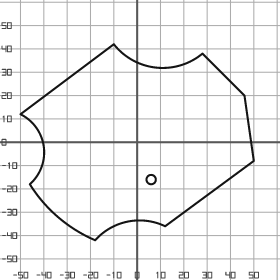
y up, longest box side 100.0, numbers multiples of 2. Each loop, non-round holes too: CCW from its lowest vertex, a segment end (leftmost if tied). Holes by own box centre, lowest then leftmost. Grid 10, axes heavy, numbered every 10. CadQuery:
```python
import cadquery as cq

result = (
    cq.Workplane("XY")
    .moveTo(-18.0, -42.0)
    .threePointArc((-4.0, -34.0), (12.0, -36.0))
    .lineTo(50.0, -8.0)
    .lineTo(46.0, 20.0)
    .lineTo(28.0, 38.0)
    .threePointArc((8.0, 32.0), (-10.0, 42.0))
    .lineTo(-50.0, 12.0)
    .threePointArc((-40.0, -2.0), (-46.0, -18.0))
    .threePointArc((-34.0, -32.0), (-18.0, -42.0))
    .close()
    .moveTo(6.0, -16.0)
    .circle(2.0)
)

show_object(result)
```